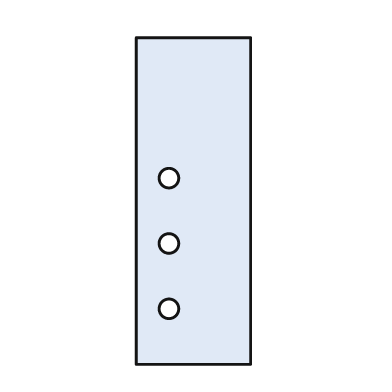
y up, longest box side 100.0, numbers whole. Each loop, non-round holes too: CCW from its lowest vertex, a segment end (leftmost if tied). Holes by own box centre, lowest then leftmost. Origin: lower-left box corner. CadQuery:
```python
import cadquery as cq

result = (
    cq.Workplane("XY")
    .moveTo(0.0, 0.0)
    .lineTo(35.0, 0.0)
    .lineTo(35.0, 100.0)
    .lineTo(0.0, 100.0)
    .close()
    .moveTo(10.0, 17.0)
    .circle(3.0)
    .moveTo(10.0, 37.0)
    .circle(3.0)
    .moveTo(10.0, 57.0)
    .circle(3.0)
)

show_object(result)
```